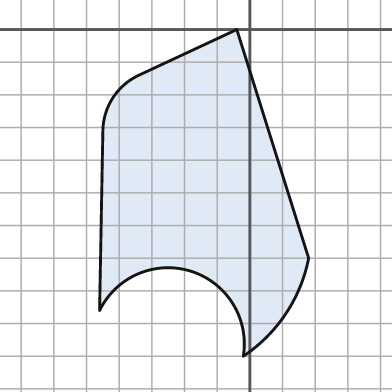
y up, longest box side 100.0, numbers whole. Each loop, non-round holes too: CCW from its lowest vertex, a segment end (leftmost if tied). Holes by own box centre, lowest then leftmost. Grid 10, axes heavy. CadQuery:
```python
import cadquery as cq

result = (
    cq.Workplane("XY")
    .moveTo(-2.0, -100.0)
    .threePointArc((11.0, -87.0), (18.0, -70.0))
    .lineTo(-4.0, 0.0)
    .lineTo(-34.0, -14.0)
    .threePointArc((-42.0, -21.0), (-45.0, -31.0))
    .lineTo(-46.0, -86.0)
    .threePointArc((-18.0, -74.0), (-2.0, -100.0))
    .close()
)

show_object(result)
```